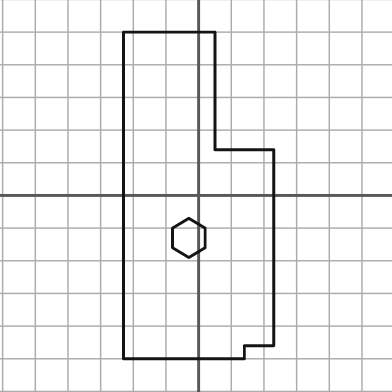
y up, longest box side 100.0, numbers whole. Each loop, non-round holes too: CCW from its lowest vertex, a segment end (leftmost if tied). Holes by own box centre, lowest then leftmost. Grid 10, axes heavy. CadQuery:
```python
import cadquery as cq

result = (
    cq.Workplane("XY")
    .moveTo(-23.0, -50.0)
    .lineTo(14.0, -50.0)
    .lineTo(14.0, -46.0)
    .lineTo(23.0, -46.0)
    .lineTo(23.0, 14.0)
    .lineTo(5.0, 14.0)
    .lineTo(5.0, 50.0)
    .lineTo(-23.0, 50.0)
    .close()
    .moveTo(-3.0, -19.0)
    .lineTo(2.0, -16.0)
    .lineTo(2.0, -10.0)
    .lineTo(-3.0, -7.0)
    .lineTo(-8.0, -10.0)
    .lineTo(-8.0, -16.0)
    .close()
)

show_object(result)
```